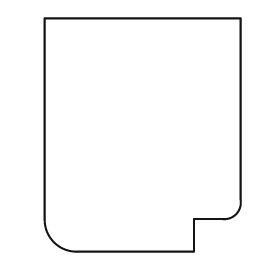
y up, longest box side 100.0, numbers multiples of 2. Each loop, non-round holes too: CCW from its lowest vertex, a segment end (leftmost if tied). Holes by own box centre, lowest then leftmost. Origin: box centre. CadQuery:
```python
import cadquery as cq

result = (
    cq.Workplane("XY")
    .moveTo(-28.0, -50.0)
    .lineTo(22.0, -50.0)
    .lineTo(22.0, -36.0)
    .lineTo(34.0, -36.0)
    .threePointArc((40.0, -34.0), (42.0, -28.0))
    .lineTo(42.0, 50.0)
    .lineTo(-42.0, 50.0)
    .lineTo(-42.0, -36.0)
    .threePointArc((-38.0, -46.0), (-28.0, -50.0))
    .close()
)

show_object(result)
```